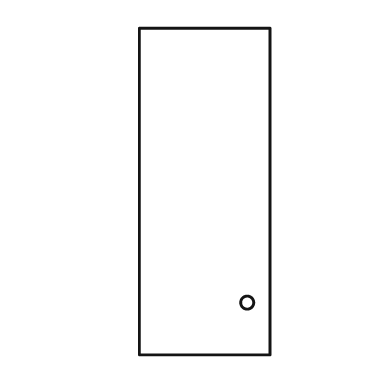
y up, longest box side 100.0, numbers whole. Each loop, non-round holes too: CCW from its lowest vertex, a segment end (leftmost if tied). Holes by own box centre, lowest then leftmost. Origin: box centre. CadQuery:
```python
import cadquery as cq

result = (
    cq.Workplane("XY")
    .moveTo(-20.0, -50.0)
    .lineTo(20.0, -50.0)
    .lineTo(20.0, 50.0)
    .lineTo(-20.0, 50.0)
    .close()
    .moveTo(13.0, -34.0)
    .circle(2.0)
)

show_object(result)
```